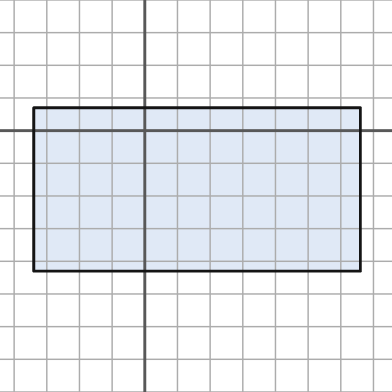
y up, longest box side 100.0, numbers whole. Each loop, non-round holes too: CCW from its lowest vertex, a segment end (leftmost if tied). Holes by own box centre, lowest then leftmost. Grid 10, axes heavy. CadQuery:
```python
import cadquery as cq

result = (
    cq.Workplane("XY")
    .moveTo(-34.0, -43.0)
    .lineTo(66.0, -43.0)
    .lineTo(66.0, 7.0)
    .lineTo(-34.0, 7.0)
    .close()
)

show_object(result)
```